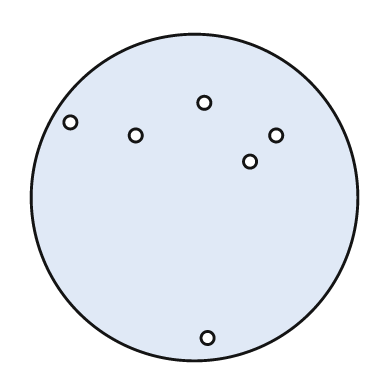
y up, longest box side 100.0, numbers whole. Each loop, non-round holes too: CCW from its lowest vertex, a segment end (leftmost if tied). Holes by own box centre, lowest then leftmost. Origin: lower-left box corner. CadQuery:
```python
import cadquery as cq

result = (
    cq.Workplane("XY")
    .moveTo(50.0, 50.0)
    .circle(50.0)
    .moveTo(54.0, 7.0)
    .circle(2.0)
    .moveTo(67.0, 61.0)
    .circle(2.0)
    .moveTo(32.0, 69.0)
    .circle(2.0)
    .moveTo(75.0, 69.0)
    .circle(2.0)
    .moveTo(12.0, 73.0)
    .circle(2.0)
    .moveTo(53.0, 79.0)
    .circle(2.0)
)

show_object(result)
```